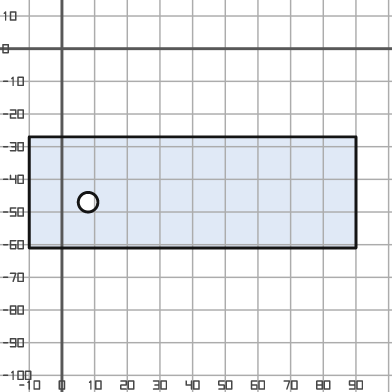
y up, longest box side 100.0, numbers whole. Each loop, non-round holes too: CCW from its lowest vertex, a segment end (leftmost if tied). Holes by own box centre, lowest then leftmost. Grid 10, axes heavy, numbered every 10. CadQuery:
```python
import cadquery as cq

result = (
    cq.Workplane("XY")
    .moveTo(-10.0, -61.0)
    .lineTo(90.0, -61.0)
    .lineTo(90.0, -27.0)
    .lineTo(-10.0, -27.0)
    .close()
    .moveTo(8.0, -47.0)
    .circle(3.0)
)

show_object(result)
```